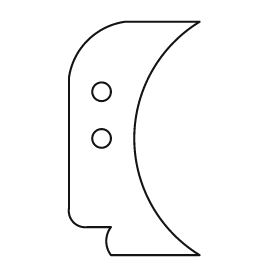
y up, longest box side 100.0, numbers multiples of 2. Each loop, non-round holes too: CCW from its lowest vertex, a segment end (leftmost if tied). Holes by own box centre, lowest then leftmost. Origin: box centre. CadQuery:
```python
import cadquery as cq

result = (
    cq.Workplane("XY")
    .moveTo(-10.0, -50.0)
    .lineTo(28.0, -50.0)
    .threePointArc((0.0, 0.0), (28.0, 50.0))
    .lineTo(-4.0, 50.0)
    .threePointArc((-20.0, 42.0), (-28.0, 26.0))
    .lineTo(-28.0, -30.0)
    .threePointArc((-26.0, -36.0), (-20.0, -38.0))
    .lineTo(-10.0, -38.0)
    .threePointArc((-12.0, -44.0), (-10.0, -50.0))
    .close()
    .moveTo(-14.0, 0.0)
    .circle(4.0)
    .moveTo(-14.0, 20.0)
    .circle(4.0)
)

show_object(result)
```